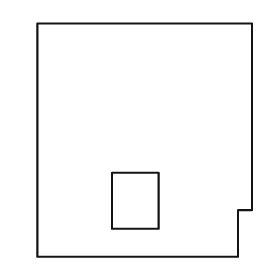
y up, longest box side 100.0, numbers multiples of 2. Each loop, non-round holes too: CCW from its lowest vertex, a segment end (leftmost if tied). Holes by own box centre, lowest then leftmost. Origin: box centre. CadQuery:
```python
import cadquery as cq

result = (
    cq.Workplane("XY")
    .moveTo(-46.0, -50.0)
    .lineTo(40.0, -50.0)
    .lineTo(40.0, -30.0)
    .lineTo(46.0, -30.0)
    .lineTo(46.0, 50.0)
    .lineTo(-46.0, 50.0)
    .close()
    .moveTo(-14.0, -38.0)
    .lineTo(6.0, -38.0)
    .lineTo(6.0, -14.0)
    .lineTo(-14.0, -14.0)
    .close()
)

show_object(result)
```